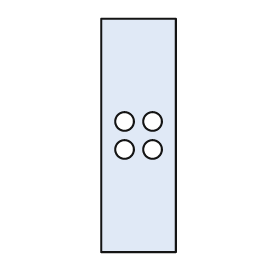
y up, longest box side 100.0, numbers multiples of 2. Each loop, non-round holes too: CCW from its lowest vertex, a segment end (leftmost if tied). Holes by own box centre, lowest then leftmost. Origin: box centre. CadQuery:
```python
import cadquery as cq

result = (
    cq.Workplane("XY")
    .moveTo(-16.0, -50.0)
    .lineTo(16.0, -50.0)
    .lineTo(16.0, 50.0)
    .lineTo(-16.0, 50.0)
    .close()
    .moveTo(-6.0, -6.0)
    .circle(4.0)
    .moveTo(6.0, -6.0)
    .circle(4.0)
    .moveTo(-6.0, 6.0)
    .circle(4.0)
    .moveTo(6.0, 6.0)
    .circle(4.0)
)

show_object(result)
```